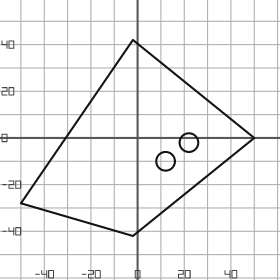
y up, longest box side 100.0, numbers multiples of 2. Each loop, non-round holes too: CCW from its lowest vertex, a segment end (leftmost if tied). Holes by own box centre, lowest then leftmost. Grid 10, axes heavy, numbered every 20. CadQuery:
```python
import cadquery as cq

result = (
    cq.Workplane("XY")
    .moveTo(-2.0, -42.0)
    .lineTo(50.0, 0.0)
    .lineTo(-2.0, 42.0)
    .lineTo(-50.0, -28.0)
    .close()
    .moveTo(12.0, -10.0)
    .circle(4.0)
    .moveTo(22.0, -2.0)
    .circle(4.0)
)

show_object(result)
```